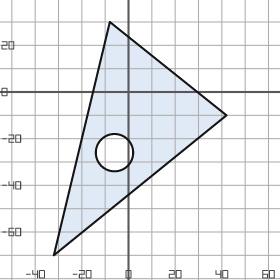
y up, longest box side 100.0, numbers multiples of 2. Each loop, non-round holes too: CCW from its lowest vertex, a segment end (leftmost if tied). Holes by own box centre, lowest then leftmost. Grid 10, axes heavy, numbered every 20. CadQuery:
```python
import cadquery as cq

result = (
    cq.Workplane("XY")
    .moveTo(-32.0, -70.0)
    .lineTo(42.0, -10.0)
    .lineTo(-8.0, 30.0)
    .close()
    .moveTo(-6.0, -26.0)
    .circle(8.0)
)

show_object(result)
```